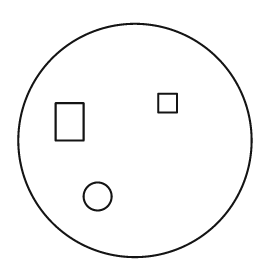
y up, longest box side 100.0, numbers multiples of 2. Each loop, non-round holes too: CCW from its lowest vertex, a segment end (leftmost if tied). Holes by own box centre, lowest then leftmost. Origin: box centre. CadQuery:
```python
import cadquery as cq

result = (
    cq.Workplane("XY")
    .moveTo(0.0, 0.0)
    .circle(50.0)
    .moveTo(-16.0, -24.0)
    .circle(6.0)
    .moveTo(-34.0, 0.0)
    .lineTo(-22.0, 0.0)
    .lineTo(-22.0, 16.0)
    .lineTo(-34.0, 16.0)
    .close()
    .moveTo(10.0, 12.0)
    .lineTo(18.0, 12.0)
    .lineTo(18.0, 20.0)
    .lineTo(10.0, 20.0)
    .close()
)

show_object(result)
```